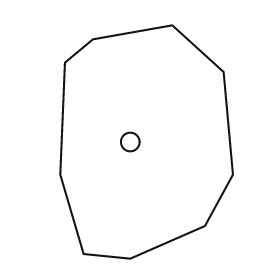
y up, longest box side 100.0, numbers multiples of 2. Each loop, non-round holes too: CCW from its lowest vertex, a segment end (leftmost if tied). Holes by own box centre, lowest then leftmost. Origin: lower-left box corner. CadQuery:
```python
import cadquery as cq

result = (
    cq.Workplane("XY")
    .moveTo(30.0, 0.0)
    .lineTo(62.0, 14.0)
    .lineTo(74.0, 36.0)
    .lineTo(70.0, 80.0)
    .lineTo(48.0, 100.0)
    .lineTo(14.0, 94.0)
    .lineTo(2.0, 84.0)
    .lineTo(0.0, 36.0)
    .lineTo(10.0, 2.0)
    .close()
    .moveTo(30.0, 50.0)
    .circle(4.0)
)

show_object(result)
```